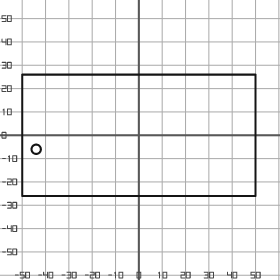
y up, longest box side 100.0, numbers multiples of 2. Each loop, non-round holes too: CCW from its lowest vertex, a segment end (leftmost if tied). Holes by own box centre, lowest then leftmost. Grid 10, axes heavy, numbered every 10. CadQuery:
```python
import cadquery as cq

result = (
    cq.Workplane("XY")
    .moveTo(-50.0, -26.0)
    .lineTo(50.0, -26.0)
    .lineTo(50.0, 26.0)
    .lineTo(-50.0, 26.0)
    .close()
    .moveTo(-44.0, -6.0)
    .circle(2.0)
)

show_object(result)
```